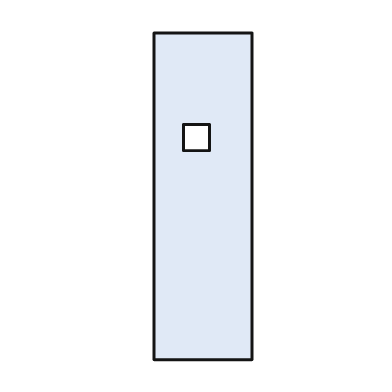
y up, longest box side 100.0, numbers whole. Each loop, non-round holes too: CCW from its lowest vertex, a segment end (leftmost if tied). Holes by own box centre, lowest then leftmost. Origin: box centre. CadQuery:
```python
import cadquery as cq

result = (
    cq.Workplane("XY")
    .moveTo(-15.0, -50.0)
    .lineTo(15.0, -50.0)
    .lineTo(15.0, 50.0)
    .lineTo(-15.0, 50.0)
    .close()
    .moveTo(-6.0, 14.0)
    .lineTo(2.0, 14.0)
    .lineTo(2.0, 22.0)
    .lineTo(-6.0, 22.0)
    .close()
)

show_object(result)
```